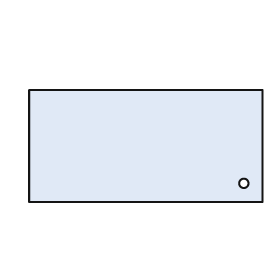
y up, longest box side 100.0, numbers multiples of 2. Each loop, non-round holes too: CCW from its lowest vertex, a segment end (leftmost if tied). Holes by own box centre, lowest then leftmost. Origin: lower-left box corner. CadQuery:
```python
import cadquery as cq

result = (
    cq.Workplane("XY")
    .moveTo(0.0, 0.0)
    .lineTo(100.0, 0.0)
    .lineTo(100.0, 48.0)
    .lineTo(0.0, 48.0)
    .close()
    .moveTo(92.0, 8.0)
    .circle(2.0)
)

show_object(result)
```